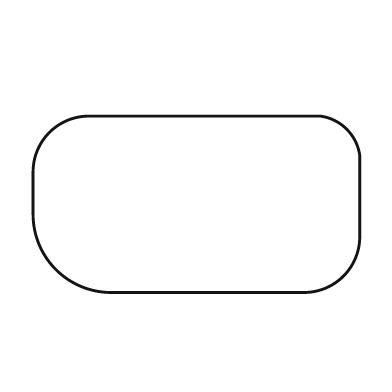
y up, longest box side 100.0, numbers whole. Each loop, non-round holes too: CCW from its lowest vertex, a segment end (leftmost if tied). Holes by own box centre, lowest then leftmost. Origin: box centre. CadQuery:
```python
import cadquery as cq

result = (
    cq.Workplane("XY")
    .moveTo(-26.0, -27.0)
    .lineTo(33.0, -27.0)
    .threePointArc((45.0, -22.0), (50.0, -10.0))
    .lineTo(50.0, 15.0)
    .threePointArc((46.0, 23.0), (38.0, 27.0))
    .lineTo(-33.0, 27.0)
    .threePointArc((-45.0, 22.0), (-50.0, 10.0))
    .lineTo(-50.0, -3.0)
    .threePointArc((-43.0, -20.0), (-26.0, -27.0))
    .close()
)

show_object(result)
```